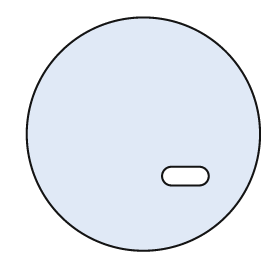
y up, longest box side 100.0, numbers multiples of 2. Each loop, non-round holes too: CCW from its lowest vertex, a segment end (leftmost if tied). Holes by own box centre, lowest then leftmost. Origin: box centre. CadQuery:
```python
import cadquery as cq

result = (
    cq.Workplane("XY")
    .moveTo(0.0, 0.0)
    .circle(50.0)
    .moveTo(12.0, -22.0)
    .lineTo(24.0, -22.0)
    .threePointArc((28.0, -18.0), (24.0, -14.0))
    .lineTo(12.0, -14.0)
    .threePointArc((8.0, -18.0), (12.0, -22.0))
    .close()
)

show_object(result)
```